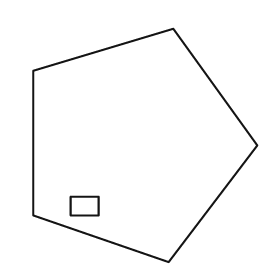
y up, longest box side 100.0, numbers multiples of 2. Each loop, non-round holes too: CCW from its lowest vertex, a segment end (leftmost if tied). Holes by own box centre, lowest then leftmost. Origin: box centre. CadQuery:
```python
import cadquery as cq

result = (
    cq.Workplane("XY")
    .moveTo(10.0, -50.0)
    .lineTo(48.0, 0.0)
    .lineTo(12.0, 50.0)
    .lineTo(-48.0, 32.0)
    .lineTo(-48.0, -30.0)
    .close()
    .moveTo(-32.0, -30.0)
    .lineTo(-20.0, -30.0)
    .lineTo(-20.0, -22.0)
    .lineTo(-32.0, -22.0)
    .close()
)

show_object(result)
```